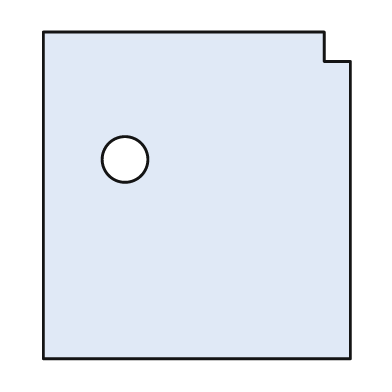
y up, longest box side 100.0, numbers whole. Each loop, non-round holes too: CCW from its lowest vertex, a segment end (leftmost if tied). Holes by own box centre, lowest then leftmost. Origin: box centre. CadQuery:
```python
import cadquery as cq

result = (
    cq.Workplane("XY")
    .moveTo(-47.0, -50.0)
    .lineTo(47.0, -50.0)
    .lineTo(47.0, 41.0)
    .lineTo(39.0, 41.0)
    .lineTo(39.0, 50.0)
    .lineTo(-47.0, 50.0)
    .close()
    .moveTo(-22.0, 11.0)
    .circle(7.0)
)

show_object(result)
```